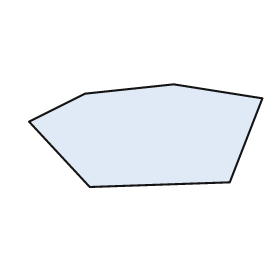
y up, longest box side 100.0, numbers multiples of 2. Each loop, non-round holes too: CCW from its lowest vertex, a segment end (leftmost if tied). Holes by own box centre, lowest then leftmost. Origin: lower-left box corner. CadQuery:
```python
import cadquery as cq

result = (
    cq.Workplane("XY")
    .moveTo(26.0, 0.0)
    .lineTo(86.0, 2.0)
    .lineTo(100.0, 38.0)
    .lineTo(62.0, 44.0)
    .lineTo(24.0, 40.0)
    .lineTo(0.0, 28.0)
    .close()
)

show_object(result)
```